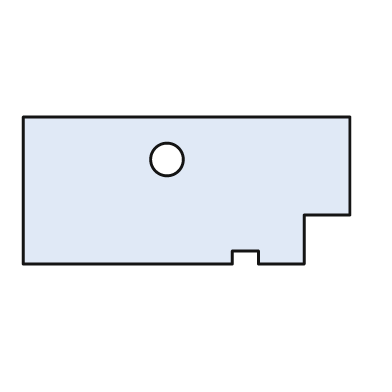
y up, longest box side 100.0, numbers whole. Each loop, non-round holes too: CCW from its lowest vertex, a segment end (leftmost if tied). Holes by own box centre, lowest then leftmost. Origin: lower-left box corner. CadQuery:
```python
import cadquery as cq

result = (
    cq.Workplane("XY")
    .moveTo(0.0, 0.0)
    .lineTo(64.0, 0.0)
    .lineTo(64.0, 4.0)
    .lineTo(72.0, 4.0)
    .lineTo(72.0, 0.0)
    .lineTo(86.0, 0.0)
    .lineTo(86.0, 15.0)
    .lineTo(100.0, 15.0)
    .lineTo(100.0, 45.0)
    .lineTo(0.0, 45.0)
    .close()
    .moveTo(44.0, 32.0)
    .circle(5.0)
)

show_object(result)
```